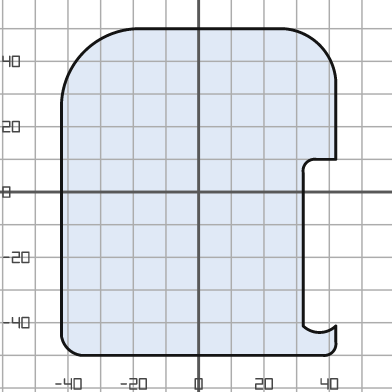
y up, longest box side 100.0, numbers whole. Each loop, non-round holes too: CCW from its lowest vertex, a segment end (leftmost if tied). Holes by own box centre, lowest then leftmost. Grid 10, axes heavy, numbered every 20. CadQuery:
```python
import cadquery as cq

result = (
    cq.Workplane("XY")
    .moveTo(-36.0, -50.0)
    .lineTo(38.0, -50.0)
    .threePointArc((41.0, -49.0), (42.0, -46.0))
    .lineTo(42.0, -41.0)
    .threePointArc((37.0, -43.0), (32.0, -41.0))
    .lineTo(32.0, 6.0)
    .threePointArc((33.0, 9.0), (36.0, 10.0))
    .lineTo(42.0, 10.0)
    .lineTo(42.0, 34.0)
    .threePointArc((37.0, 45.0), (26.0, 50.0))
    .lineTo(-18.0, 50.0)
    .threePointArc((-35.0, 43.0), (-42.0, 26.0))
    .lineTo(-42.0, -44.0)
    .threePointArc((-40.0, -48.0), (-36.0, -50.0))
    .close()
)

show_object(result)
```